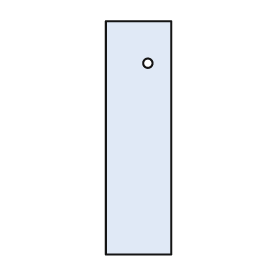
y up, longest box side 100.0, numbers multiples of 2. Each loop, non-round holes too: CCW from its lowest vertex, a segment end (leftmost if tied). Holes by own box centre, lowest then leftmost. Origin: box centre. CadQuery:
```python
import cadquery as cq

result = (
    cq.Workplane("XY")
    .moveTo(-14.0, -50.0)
    .lineTo(14.0, -50.0)
    .lineTo(14.0, 50.0)
    .lineTo(-14.0, 50.0)
    .close()
    .moveTo(4.0, 32.0)
    .circle(2.0)
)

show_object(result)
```